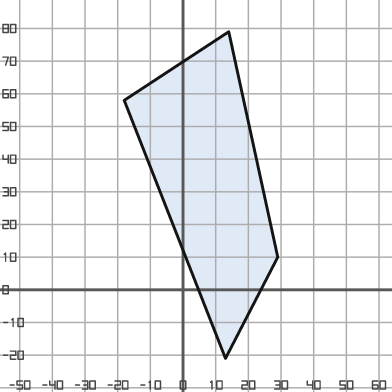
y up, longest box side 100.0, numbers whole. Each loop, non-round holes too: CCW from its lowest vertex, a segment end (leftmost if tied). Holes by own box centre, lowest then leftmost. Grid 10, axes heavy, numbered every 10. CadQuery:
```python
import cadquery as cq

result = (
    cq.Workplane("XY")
    .moveTo(13.0, -21.0)
    .lineTo(29.0, 10.0)
    .lineTo(14.0, 79.0)
    .lineTo(-18.0, 58.0)
    .close()
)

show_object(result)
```